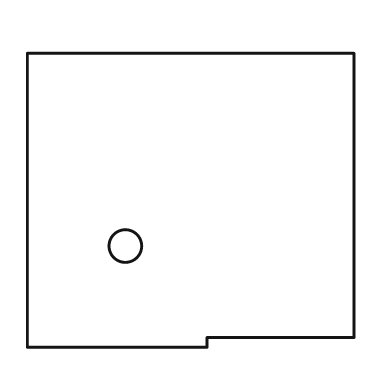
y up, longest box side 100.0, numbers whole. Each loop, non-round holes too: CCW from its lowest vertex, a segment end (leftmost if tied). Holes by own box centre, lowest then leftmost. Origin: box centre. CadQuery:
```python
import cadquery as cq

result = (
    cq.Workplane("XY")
    .moveTo(-50.0, -45.0)
    .lineTo(5.0, -45.0)
    .lineTo(5.0, -42.0)
    .lineTo(50.0, -42.0)
    .lineTo(50.0, 45.0)
    .lineTo(-50.0, 45.0)
    .close()
    .moveTo(-20.0, -14.0)
    .circle(5.0)
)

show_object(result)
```